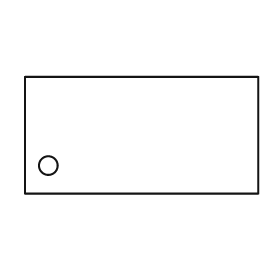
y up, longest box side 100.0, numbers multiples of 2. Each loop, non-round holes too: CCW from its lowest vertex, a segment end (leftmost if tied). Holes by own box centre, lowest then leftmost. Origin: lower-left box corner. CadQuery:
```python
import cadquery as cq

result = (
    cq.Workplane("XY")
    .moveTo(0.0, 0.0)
    .lineTo(100.0, 0.0)
    .lineTo(100.0, 50.0)
    .lineTo(0.0, 50.0)
    .close()
    .moveTo(10.0, 12.0)
    .circle(4.0)
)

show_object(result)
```